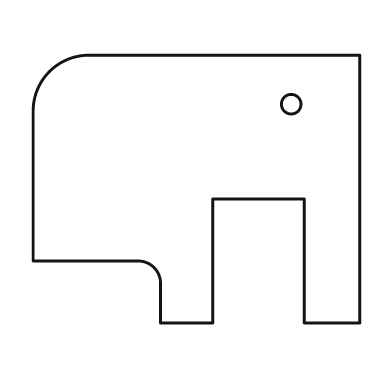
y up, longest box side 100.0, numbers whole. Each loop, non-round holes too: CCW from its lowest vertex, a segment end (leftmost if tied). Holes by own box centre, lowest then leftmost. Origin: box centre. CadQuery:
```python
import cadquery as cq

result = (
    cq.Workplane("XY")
    .moveTo(-11.0, -41.0)
    .lineTo(5.0, -41.0)
    .lineTo(5.0, -3.0)
    .lineTo(33.0, -3.0)
    .lineTo(33.0, -41.0)
    .lineTo(50.0, -41.0)
    .lineTo(50.0, 41.0)
    .lineTo(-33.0, 41.0)
    .threePointArc((-45.0, 36.0), (-50.0, 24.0))
    .lineTo(-50.0, -22.0)
    .lineTo(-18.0, -22.0)
    .threePointArc((-13.0, -24.0), (-11.0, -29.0))
    .close()
    .moveTo(29.0, 26.0)
    .circle(3.0)
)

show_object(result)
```